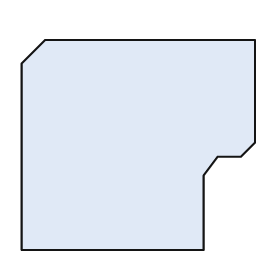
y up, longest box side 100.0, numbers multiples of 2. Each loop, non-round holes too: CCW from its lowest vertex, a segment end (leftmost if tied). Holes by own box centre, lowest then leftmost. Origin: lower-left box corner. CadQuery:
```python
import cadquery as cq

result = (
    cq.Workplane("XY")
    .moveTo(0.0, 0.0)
    .lineTo(78.0, 0.0)
    .lineTo(78.0, 32.0)
    .lineTo(84.0, 40.0)
    .lineTo(94.0, 40.0)
    .lineTo(100.0, 46.0)
    .lineTo(100.0, 90.0)
    .lineTo(10.0, 90.0)
    .lineTo(0.0, 80.0)
    .close()
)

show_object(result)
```